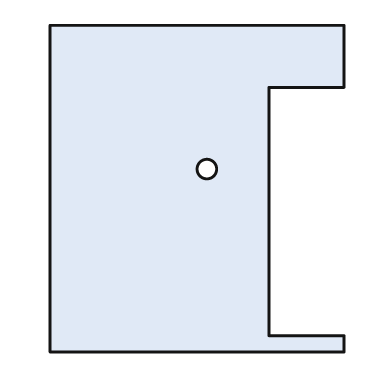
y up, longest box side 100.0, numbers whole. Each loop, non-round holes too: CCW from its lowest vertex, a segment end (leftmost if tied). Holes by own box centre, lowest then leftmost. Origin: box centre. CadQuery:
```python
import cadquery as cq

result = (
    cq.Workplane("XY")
    .moveTo(-45.0, -50.0)
    .lineTo(45.0, -50.0)
    .lineTo(45.0, -45.0)
    .lineTo(22.0, -45.0)
    .lineTo(22.0, 31.0)
    .lineTo(45.0, 31.0)
    .lineTo(45.0, 50.0)
    .lineTo(-45.0, 50.0)
    .close()
    .moveTo(3.0, 6.0)
    .circle(3.0)
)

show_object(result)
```